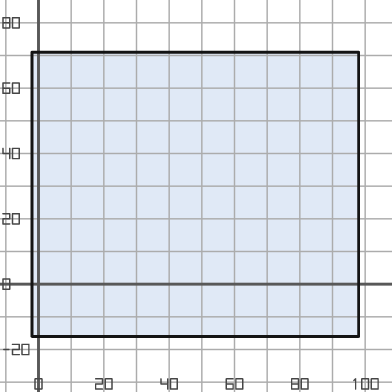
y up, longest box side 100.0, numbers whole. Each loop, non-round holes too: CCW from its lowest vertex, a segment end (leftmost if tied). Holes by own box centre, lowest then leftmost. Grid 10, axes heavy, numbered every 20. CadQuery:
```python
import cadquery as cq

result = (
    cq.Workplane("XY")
    .moveTo(-2.0, -16.0)
    .lineTo(98.0, -16.0)
    .lineTo(98.0, 71.0)
    .lineTo(-2.0, 71.0)
    .close()
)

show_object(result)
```